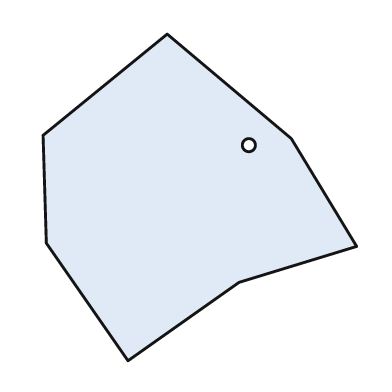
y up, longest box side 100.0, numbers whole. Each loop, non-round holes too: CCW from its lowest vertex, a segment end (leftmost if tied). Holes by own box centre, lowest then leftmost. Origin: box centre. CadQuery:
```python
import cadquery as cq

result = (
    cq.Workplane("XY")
    .moveTo(-22.0, -50.0)
    .lineTo(12.0, -26.0)
    .lineTo(48.0, -15.0)
    .lineTo(28.0, 18.0)
    .lineTo(-10.0, 50.0)
    .lineTo(-48.0, 19.0)
    .lineTo(-47.0, -14.0)
    .close()
    .moveTo(15.0, 16.0)
    .circle(2.0)
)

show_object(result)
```